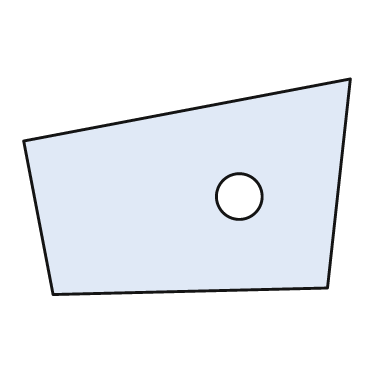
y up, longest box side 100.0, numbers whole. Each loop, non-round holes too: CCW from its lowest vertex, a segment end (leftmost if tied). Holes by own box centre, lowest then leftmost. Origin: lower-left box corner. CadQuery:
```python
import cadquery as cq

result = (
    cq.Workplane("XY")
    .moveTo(9.0, 0.0)
    .lineTo(93.0, 2.0)
    .lineTo(100.0, 66.0)
    .lineTo(0.0, 47.0)
    .close()
    .moveTo(66.0, 30.0)
    .circle(7.0)
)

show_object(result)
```